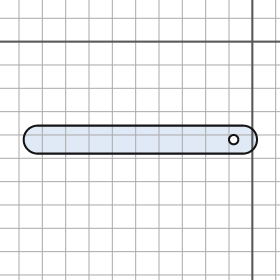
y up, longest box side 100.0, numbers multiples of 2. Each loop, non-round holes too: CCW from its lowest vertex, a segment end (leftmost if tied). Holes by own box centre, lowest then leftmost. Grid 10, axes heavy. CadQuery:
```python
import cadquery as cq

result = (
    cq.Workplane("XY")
    .moveTo(-92.0, -48.0)
    .lineTo(-4.0, -48.0)
    .threePointArc((2.0, -42.0), (-4.0, -36.0))
    .lineTo(-92.0, -36.0)
    .threePointArc((-98.0, -42.0), (-92.0, -48.0))
    .close()
    .moveTo(-8.0, -42.0)
    .circle(2.0)
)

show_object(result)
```